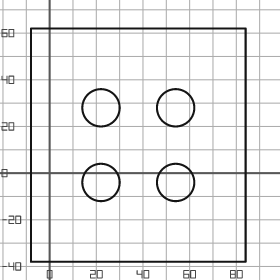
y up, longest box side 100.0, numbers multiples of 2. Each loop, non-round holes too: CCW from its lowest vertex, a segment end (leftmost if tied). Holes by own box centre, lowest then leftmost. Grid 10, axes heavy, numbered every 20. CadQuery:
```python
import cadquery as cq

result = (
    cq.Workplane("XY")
    .moveTo(-8.0, -38.0)
    .lineTo(84.0, -38.0)
    .lineTo(84.0, 62.0)
    .lineTo(-8.0, 62.0)
    .close()
    .moveTo(22.0, -4.0)
    .circle(8.0)
    .moveTo(54.0, -4.0)
    .circle(8.0)
    .moveTo(22.0, 28.0)
    .circle(8.0)
    .moveTo(54.0, 28.0)
    .circle(8.0)
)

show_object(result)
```